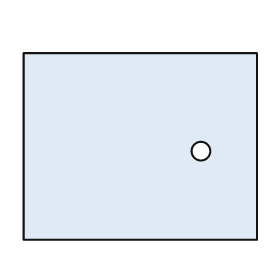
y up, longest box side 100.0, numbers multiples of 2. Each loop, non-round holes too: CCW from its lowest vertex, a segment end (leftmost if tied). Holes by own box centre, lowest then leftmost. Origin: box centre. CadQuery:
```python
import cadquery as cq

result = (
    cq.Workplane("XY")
    .moveTo(-50.0, -40.0)
    .lineTo(50.0, -40.0)
    .lineTo(50.0, 40.0)
    .lineTo(-50.0, 40.0)
    .close()
    .moveTo(26.0, -2.0)
    .circle(4.0)
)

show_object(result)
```